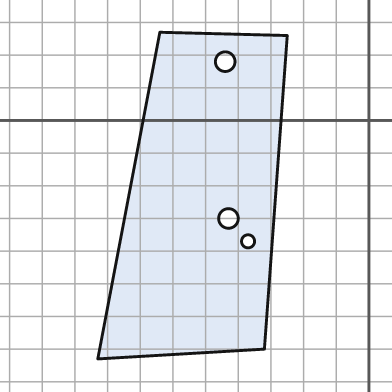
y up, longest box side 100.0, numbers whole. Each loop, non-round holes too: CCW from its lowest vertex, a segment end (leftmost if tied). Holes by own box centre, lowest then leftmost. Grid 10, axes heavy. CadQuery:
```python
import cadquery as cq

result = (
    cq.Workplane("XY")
    .moveTo(-83.0, -73.0)
    .lineTo(-32.0, -70.0)
    .lineTo(-25.0, 26.0)
    .lineTo(-64.0, 27.0)
    .close()
    .moveTo(-37.0, -37.0)
    .circle(2.0)
    .moveTo(-43.0, -30.0)
    .circle(3.0)
    .moveTo(-44.0, 18.0)
    .circle(3.0)
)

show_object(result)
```